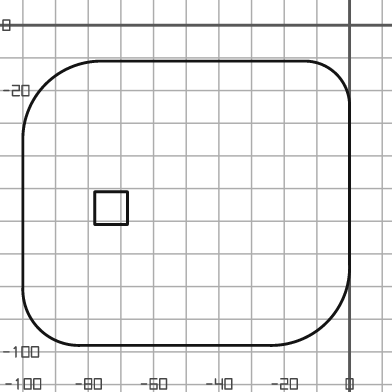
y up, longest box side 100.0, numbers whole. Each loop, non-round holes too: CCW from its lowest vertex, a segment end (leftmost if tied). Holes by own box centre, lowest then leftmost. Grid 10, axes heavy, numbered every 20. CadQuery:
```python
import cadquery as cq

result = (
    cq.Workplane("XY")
    .moveTo(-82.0, -98.0)
    .lineTo(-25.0, -98.0)
    .threePointArc((-7.0, -91.0), (0.0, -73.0))
    .lineTo(0.0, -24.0)
    .threePointArc((-4.0, -15.0), (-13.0, -11.0))
    .lineTo(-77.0, -11.0)
    .threePointArc((-93.0, -18.0), (-100.0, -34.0))
    .lineTo(-100.0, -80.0)
    .threePointArc((-95.0, -93.0), (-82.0, -98.0))
    .close()
    .moveTo(-78.0, -61.0)
    .lineTo(-68.0, -61.0)
    .lineTo(-68.0, -51.0)
    .lineTo(-78.0, -51.0)
    .close()
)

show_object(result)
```